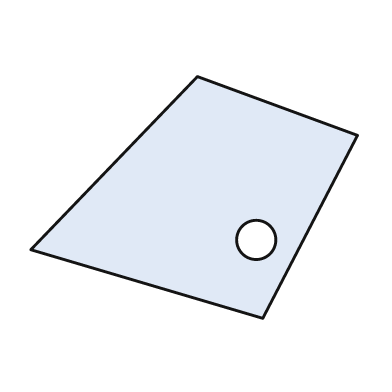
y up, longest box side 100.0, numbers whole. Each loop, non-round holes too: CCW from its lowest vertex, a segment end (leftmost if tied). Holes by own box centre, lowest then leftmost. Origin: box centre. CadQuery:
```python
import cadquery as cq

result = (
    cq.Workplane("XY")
    .moveTo(21.0, -37.0)
    .lineTo(50.0, 19.0)
    .lineTo(1.0, 37.0)
    .lineTo(-50.0, -16.0)
    .close()
    .moveTo(19.0, -13.0)
    .circle(6.0)
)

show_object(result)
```